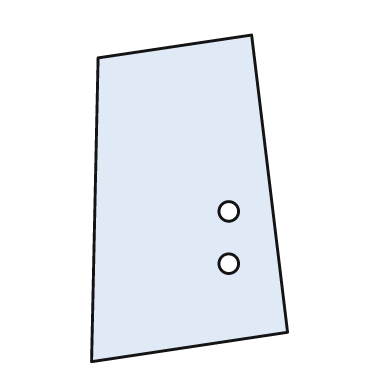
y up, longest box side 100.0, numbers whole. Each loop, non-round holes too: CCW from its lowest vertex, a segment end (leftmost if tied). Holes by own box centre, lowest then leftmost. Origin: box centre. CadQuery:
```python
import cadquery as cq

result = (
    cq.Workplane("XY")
    .moveTo(-30.0, -50.0)
    .lineTo(30.0, -41.0)
    .lineTo(19.0, 50.0)
    .lineTo(-28.0, 43.0)
    .close()
    .moveTo(12.0, -20.0)
    .circle(3.0)
    .moveTo(12.0, -4.0)
    .circle(3.0)
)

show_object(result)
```